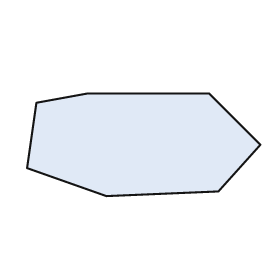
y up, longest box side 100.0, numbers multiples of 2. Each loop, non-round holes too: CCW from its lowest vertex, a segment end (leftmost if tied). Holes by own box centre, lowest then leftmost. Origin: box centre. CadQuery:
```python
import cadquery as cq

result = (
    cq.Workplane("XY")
    .moveTo(-16.0, -22.0)
    .lineTo(32.0, -20.0)
    .lineTo(50.0, 0.0)
    .lineTo(28.0, 22.0)
    .lineTo(-24.0, 22.0)
    .lineTo(-46.0, 18.0)
    .lineTo(-50.0, -10.0)
    .close()
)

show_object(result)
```